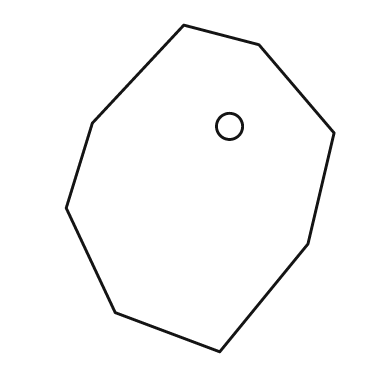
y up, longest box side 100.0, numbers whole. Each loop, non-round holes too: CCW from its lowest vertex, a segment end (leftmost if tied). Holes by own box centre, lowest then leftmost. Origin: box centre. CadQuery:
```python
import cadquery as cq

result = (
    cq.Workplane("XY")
    .moveTo(6.0, -50.0)
    .lineTo(33.0, -17.0)
    .lineTo(41.0, 17.0)
    .lineTo(18.0, 44.0)
    .lineTo(-5.0, 50.0)
    .lineTo(-33.0, 20.0)
    .lineTo(-41.0, -6.0)
    .lineTo(-26.0, -38.0)
    .close()
    .moveTo(9.0, 19.0)
    .circle(4.0)
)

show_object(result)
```